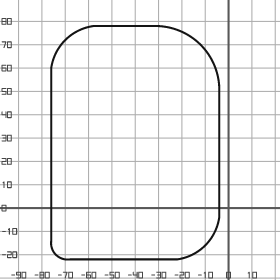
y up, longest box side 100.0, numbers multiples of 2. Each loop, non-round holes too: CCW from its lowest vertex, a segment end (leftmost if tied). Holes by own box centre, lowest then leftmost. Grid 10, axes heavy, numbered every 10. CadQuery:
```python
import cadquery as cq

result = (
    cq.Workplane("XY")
    .moveTo(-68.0, -22.0)
    .lineTo(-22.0, -22.0)
    .threePointArc((-10.0, -16.0), (-4.0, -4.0))
    .lineTo(-4.0, 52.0)
    .threePointArc((-12.0, 70.0), (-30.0, 78.0))
    .lineTo(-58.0, 78.0)
    .threePointArc((-70.0, 72.0), (-76.0, 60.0))
    .lineTo(-76.0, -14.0)
    .threePointArc((-74.0, -20.0), (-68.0, -22.0))
    .close()
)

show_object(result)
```